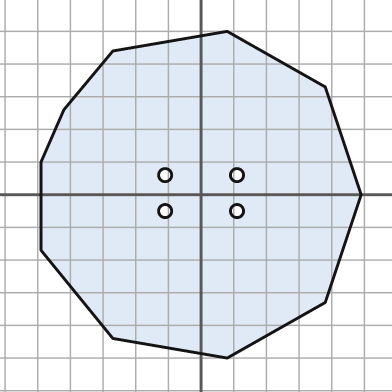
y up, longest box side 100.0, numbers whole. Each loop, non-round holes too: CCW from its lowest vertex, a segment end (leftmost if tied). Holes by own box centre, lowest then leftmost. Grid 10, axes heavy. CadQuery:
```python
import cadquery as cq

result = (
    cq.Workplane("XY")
    .moveTo(8.0, -50.0)
    .lineTo(38.0, -33.0)
    .lineTo(49.0, 0.0)
    .lineTo(38.0, 33.0)
    .lineTo(8.0, 50.0)
    .lineTo(-27.0, 44.0)
    .lineTo(-42.0, 26.0)
    .lineTo(-49.0, 10.0)
    .lineTo(-49.0, -17.0)
    .lineTo(-27.0, -44.0)
    .close()
    .moveTo(-11.0, -5.0)
    .circle(2.0)
    .moveTo(11.0, -5.0)
    .circle(2.0)
    .moveTo(-11.0, 6.0)
    .circle(2.0)
    .moveTo(11.0, 6.0)
    .circle(2.0)
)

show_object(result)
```